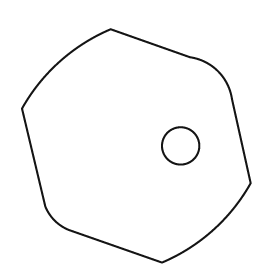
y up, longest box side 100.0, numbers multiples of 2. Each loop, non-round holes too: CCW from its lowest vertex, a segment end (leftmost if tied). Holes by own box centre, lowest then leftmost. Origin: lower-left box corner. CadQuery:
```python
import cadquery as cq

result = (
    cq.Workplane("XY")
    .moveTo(60.0, 0.0)
    .threePointArc((82.0, 14.0), (98.0, 34.0))
    .lineTo(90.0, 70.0)
    .threePointArc((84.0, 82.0), (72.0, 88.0))
    .lineTo(38.0, 100.0)
    .threePointArc((16.0, 86.0), (0.0, 66.0))
    .lineTo(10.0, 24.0)
    .threePointArc((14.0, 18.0), (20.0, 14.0))
    .close()
    .moveTo(68.0, 50.0)
    .circle(8.0)
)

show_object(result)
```